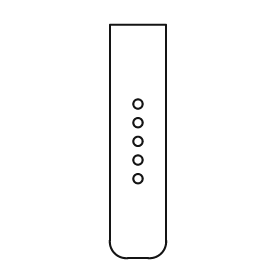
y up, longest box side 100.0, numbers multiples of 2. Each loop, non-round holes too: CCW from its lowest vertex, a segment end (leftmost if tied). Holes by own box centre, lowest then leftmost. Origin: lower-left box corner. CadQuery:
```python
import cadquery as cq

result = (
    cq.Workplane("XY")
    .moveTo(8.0, 0.0)
    .lineTo(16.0, 0.0)
    .threePointArc((22.0, 2.0), (24.0, 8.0))
    .lineTo(24.0, 100.0)
    .lineTo(0.0, 100.0)
    .lineTo(0.0, 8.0)
    .threePointArc((2.0, 2.0), (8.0, 0.0))
    .close()
    .moveTo(12.0, 34.0)
    .circle(2.0)
    .moveTo(12.0, 42.0)
    .circle(2.0)
    .moveTo(12.0, 50.0)
    .circle(2.0)
    .moveTo(12.0, 58.0)
    .circle(2.0)
    .moveTo(12.0, 66.0)
    .circle(2.0)
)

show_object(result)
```